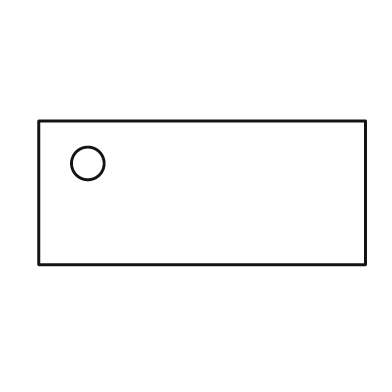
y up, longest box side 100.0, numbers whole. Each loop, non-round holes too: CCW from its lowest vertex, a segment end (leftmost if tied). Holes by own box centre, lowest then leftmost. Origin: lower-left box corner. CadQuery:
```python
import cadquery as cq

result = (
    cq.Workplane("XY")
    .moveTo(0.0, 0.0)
    .lineTo(100.0, 0.0)
    .lineTo(100.0, 44.0)
    .lineTo(0.0, 44.0)
    .close()
    .moveTo(15.0, 31.0)
    .circle(5.0)
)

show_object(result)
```